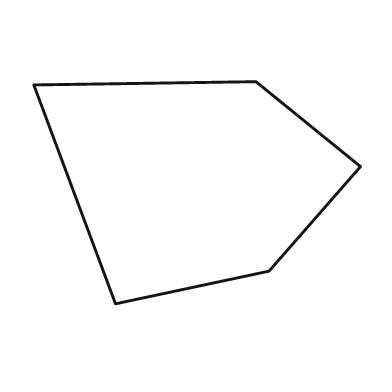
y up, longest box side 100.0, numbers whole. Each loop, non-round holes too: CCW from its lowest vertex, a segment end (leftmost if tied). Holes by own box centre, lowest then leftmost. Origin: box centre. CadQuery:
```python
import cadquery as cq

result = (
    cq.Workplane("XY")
    .moveTo(-25.0, -34.0)
    .lineTo(22.0, -24.0)
    .lineTo(50.0, 8.0)
    .lineTo(18.0, 34.0)
    .lineTo(-50.0, 33.0)
    .close()
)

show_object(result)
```